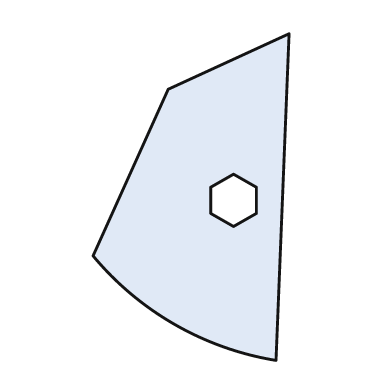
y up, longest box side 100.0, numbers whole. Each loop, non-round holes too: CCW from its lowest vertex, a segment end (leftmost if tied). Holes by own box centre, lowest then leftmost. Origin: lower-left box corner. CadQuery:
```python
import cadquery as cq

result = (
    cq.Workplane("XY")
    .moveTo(56.0, 0.0)
    .lineTo(60.0, 100.0)
    .lineTo(23.0, 83.0)
    .lineTo(0.0, 32.0)
    .threePointArc((25.0, 11.0), (56.0, 0.0))
    .close()
    .moveTo(43.0, 41.0)
    .lineTo(50.0, 45.0)
    .lineTo(50.0, 53.0)
    .lineTo(43.0, 57.0)
    .lineTo(36.0, 53.0)
    .lineTo(36.0, 45.0)
    .close()
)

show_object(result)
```